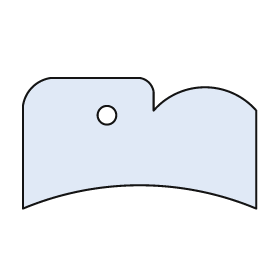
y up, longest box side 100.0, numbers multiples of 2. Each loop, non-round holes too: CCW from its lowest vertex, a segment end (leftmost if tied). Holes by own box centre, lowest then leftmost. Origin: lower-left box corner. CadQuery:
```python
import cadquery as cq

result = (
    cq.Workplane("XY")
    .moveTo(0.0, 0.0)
    .threePointArc((50.0, 10.0), (100.0, 0.0))
    .lineTo(100.0, 42.0)
    .threePointArc((78.0, 52.0), (56.0, 42.0))
    .lineTo(56.0, 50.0)
    .threePointArc((54.0, 54.0), (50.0, 56.0))
    .lineTo(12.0, 56.0)
    .threePointArc((4.0, 52.0), (0.0, 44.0))
    .close()
    .moveTo(36.0, 40.0)
    .circle(4.0)
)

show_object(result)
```